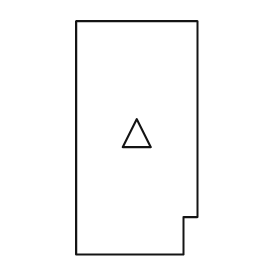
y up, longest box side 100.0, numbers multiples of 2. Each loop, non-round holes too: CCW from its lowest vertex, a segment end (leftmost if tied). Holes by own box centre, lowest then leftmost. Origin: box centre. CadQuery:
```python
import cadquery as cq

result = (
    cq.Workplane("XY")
    .moveTo(-26.0, -50.0)
    .lineTo(20.0, -50.0)
    .lineTo(20.0, -34.0)
    .lineTo(26.0, -34.0)
    .lineTo(26.0, 50.0)
    .lineTo(-26.0, 50.0)
    .close()
    .moveTo(-6.0, -4.0)
    .lineTo(6.0, -4.0)
    .lineTo(0.0, 8.0)
    .close()
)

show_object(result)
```